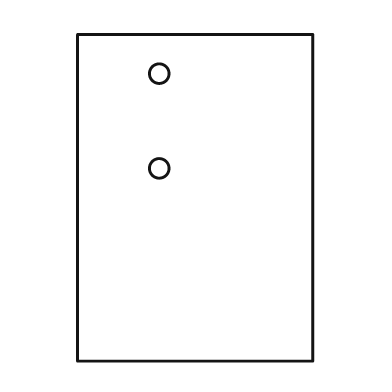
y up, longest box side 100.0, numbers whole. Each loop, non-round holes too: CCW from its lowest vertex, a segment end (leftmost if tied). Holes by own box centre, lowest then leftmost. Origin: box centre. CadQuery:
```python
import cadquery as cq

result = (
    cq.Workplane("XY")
    .moveTo(-36.0, -50.0)
    .lineTo(36.0, -50.0)
    .lineTo(36.0, 50.0)
    .lineTo(-36.0, 50.0)
    .close()
    .moveTo(-11.0, 9.0)
    .circle(3.0)
    .moveTo(-11.0, 38.0)
    .circle(3.0)
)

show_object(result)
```